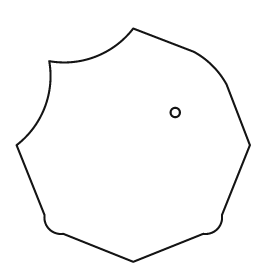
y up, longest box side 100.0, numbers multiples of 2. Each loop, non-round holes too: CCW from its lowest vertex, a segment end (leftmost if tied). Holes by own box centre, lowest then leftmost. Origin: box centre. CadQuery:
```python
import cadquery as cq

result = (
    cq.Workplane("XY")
    .moveTo(0.0, -50.0)
    .lineTo(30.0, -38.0)
    .threePointArc((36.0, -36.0), (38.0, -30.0))
    .lineTo(50.0, 0.0)
    .lineTo(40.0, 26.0)
    .threePointArc((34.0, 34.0), (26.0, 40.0))
    .lineTo(0.0, 50.0)
    .threePointArc((-16.0, 38.0), (-36.0, 36.0))
    .threePointArc((-38.0, 16.0), (-50.0, 0.0))
    .lineTo(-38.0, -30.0)
    .threePointArc((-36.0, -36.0), (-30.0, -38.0))
    .close()
    .moveTo(18.0, 14.0)
    .circle(2.0)
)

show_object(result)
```